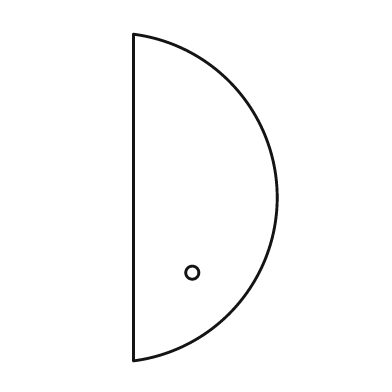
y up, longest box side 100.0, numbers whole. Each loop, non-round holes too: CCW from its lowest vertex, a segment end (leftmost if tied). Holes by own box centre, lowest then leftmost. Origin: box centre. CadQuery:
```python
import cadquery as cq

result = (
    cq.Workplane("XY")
    .moveTo(-22.0, -50.0)
    .threePointArc((22.0, 0.0), (-22.0, 50.0))
    .close()
    .moveTo(-4.0, -23.0)
    .circle(2.0)
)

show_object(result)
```